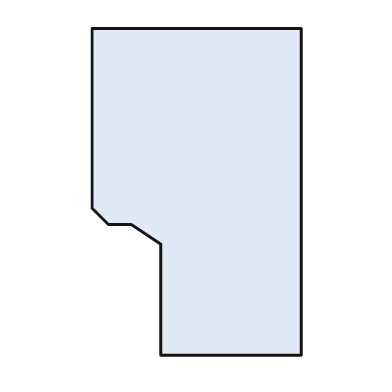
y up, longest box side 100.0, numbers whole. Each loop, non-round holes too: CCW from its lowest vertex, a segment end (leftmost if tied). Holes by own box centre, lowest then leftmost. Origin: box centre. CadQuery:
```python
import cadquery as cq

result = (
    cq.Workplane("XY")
    .moveTo(-11.0, -50.0)
    .lineTo(32.0, -50.0)
    .lineTo(32.0, 50.0)
    .lineTo(-32.0, 50.0)
    .lineTo(-32.0, -5.0)
    .lineTo(-27.0, -10.0)
    .lineTo(-20.0, -10.0)
    .lineTo(-11.0, -16.0)
    .close()
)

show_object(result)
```